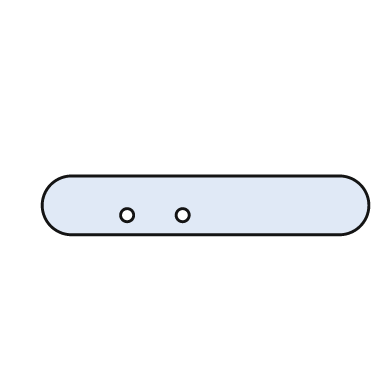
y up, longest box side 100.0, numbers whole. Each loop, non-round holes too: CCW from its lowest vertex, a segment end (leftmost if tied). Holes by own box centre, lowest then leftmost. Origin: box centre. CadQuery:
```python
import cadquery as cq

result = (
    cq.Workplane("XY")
    .moveTo(-41.0, -9.0)
    .lineTo(41.0, -9.0)
    .threePointArc((50.0, 0.0), (41.0, 9.0))
    .lineTo(-41.0, 9.0)
    .threePointArc((-50.0, 0.0), (-41.0, -9.0))
    .close()
    .moveTo(-24.0, -3.0)
    .circle(2.0)
    .moveTo(-7.0, -3.0)
    .circle(2.0)
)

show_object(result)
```